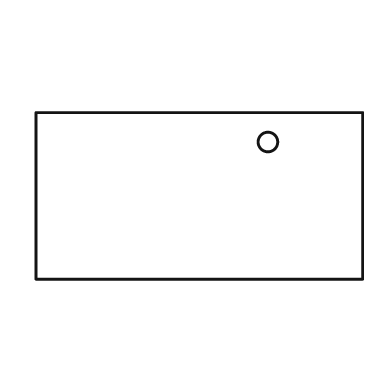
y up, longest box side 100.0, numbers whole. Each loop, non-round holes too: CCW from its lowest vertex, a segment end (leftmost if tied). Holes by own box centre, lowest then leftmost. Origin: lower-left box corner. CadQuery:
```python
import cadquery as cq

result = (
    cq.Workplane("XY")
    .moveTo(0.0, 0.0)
    .lineTo(100.0, 0.0)
    .lineTo(100.0, 51.0)
    .lineTo(0.0, 51.0)
    .close()
    .moveTo(71.0, 42.0)
    .circle(3.0)
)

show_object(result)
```